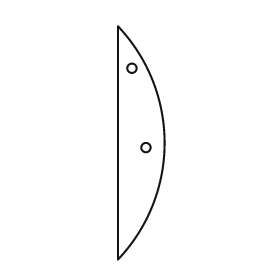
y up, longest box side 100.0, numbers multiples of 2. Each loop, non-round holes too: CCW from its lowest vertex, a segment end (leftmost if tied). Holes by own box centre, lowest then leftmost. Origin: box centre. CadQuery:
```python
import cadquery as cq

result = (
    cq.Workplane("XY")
    .moveTo(-10.0, -50.0)
    .threePointArc((10.0, 0.0), (-10.0, 50.0))
    .close()
    .moveTo(2.0, -2.0)
    .circle(2.0)
    .moveTo(-4.0, 32.0)
    .circle(2.0)
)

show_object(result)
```